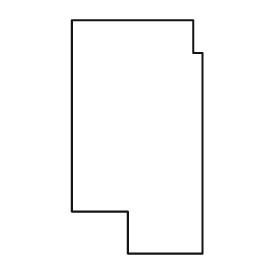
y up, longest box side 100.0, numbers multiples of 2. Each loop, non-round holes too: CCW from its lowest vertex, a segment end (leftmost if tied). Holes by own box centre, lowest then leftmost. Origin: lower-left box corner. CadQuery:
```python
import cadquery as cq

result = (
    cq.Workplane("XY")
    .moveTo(24.0, 0.0)
    .lineTo(56.0, 0.0)
    .lineTo(56.0, 86.0)
    .lineTo(52.0, 86.0)
    .lineTo(52.0, 100.0)
    .lineTo(0.0, 100.0)
    .lineTo(0.0, 18.0)
    .lineTo(24.0, 18.0)
    .close()
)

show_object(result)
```